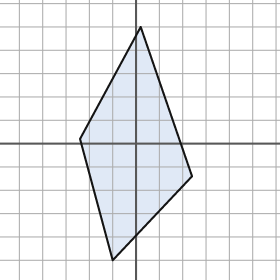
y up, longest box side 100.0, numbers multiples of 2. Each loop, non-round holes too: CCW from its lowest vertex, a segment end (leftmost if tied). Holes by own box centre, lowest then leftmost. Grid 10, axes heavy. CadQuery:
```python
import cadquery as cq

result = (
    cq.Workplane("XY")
    .moveTo(-10.0, -50.0)
    .lineTo(24.0, -14.0)
    .lineTo(2.0, 50.0)
    .lineTo(-24.0, 2.0)
    .close()
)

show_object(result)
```